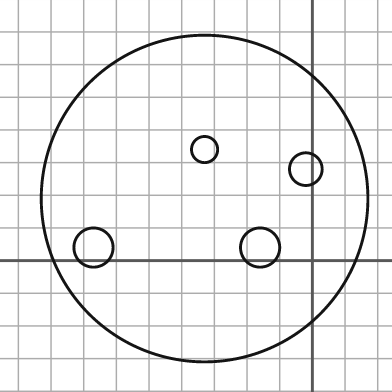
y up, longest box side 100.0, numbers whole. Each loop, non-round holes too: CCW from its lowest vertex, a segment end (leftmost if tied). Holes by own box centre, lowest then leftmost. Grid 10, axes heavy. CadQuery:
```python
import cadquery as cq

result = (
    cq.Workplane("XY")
    .moveTo(-33.0, 19.0)
    .circle(50.0)
    .moveTo(-67.0, 4.0)
    .circle(6.0)
    .moveTo(-16.0, 4.0)
    .circle(6.0)
    .moveTo(-2.0, 28.0)
    .circle(5.0)
    .moveTo(-33.0, 34.0)
    .circle(4.0)
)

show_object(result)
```